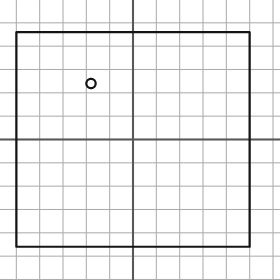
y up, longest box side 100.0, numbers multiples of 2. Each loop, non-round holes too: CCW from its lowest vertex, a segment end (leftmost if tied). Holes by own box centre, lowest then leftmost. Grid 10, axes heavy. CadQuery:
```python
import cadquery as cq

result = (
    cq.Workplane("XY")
    .moveTo(-50.0, -46.0)
    .lineTo(50.0, -46.0)
    .lineTo(50.0, 46.0)
    .lineTo(-50.0, 46.0)
    .close()
    .moveTo(-18.0, 24.0)
    .circle(2.0)
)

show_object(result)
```